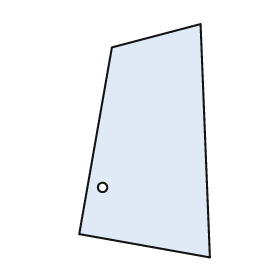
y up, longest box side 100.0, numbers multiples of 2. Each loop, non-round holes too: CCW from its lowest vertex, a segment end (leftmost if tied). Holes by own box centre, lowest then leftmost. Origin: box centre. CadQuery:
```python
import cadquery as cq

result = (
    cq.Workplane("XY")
    .moveTo(28.0, -50.0)
    .lineTo(24.0, 50.0)
    .lineTo(-14.0, 40.0)
    .lineTo(-28.0, -40.0)
    .close()
    .moveTo(-18.0, -20.0)
    .circle(2.0)
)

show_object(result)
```